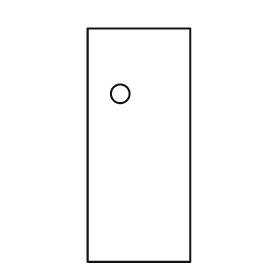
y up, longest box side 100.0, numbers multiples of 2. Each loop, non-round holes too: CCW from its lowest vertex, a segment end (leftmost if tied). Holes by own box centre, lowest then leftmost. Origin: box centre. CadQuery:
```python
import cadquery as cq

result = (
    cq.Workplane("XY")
    .moveTo(-22.0, -50.0)
    .lineTo(22.0, -50.0)
    .lineTo(22.0, 50.0)
    .lineTo(-22.0, 50.0)
    .close()
    .moveTo(-8.0, 22.0)
    .circle(4.0)
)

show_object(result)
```